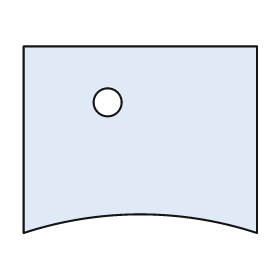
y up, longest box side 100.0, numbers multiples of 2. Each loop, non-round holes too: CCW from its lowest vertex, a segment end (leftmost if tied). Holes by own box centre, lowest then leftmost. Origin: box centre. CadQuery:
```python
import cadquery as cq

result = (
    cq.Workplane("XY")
    .moveTo(-50.0, -40.0)
    .threePointArc((0.0, -32.0), (50.0, -40.0))
    .lineTo(50.0, 40.0)
    .lineTo(-50.0, 40.0)
    .close()
    .moveTo(-14.0, 16.0)
    .circle(6.0)
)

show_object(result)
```